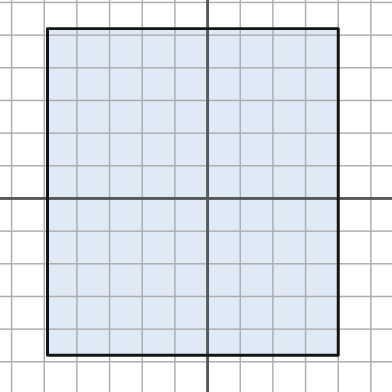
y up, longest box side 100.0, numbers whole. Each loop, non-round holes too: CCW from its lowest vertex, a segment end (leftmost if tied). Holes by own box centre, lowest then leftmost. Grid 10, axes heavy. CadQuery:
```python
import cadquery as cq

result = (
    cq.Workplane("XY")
    .moveTo(-49.0, -48.0)
    .lineTo(40.0, -48.0)
    .lineTo(40.0, 52.0)
    .lineTo(-49.0, 52.0)
    .close()
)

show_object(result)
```